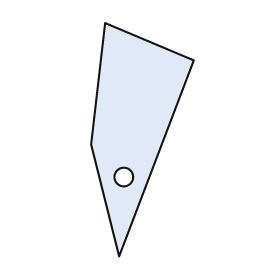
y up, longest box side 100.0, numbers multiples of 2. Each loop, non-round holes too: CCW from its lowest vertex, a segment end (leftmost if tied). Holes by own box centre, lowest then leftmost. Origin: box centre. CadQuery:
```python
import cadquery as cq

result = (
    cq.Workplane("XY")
    .moveTo(-10.0, -50.0)
    .lineTo(22.0, 34.0)
    .lineTo(-16.0, 50.0)
    .lineTo(-22.0, -2.0)
    .close()
    .moveTo(-8.0, -16.0)
    .circle(4.0)
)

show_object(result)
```